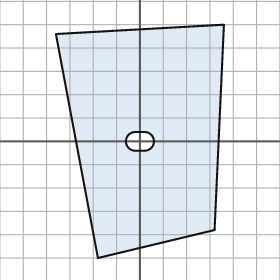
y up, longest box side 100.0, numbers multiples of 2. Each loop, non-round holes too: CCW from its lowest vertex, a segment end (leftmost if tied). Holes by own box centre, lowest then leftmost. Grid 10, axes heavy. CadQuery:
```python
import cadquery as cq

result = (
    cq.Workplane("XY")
    .moveTo(-18.0, -50.0)
    .lineTo(32.0, -38.0)
    .lineTo(36.0, 50.0)
    .lineTo(-36.0, 46.0)
    .close()
    .moveTo(-2.0, -4.0)
    .lineTo(2.0, -4.0)
    .threePointArc((6.0, 0.0), (2.0, 4.0))
    .lineTo(-2.0, 4.0)
    .threePointArc((-6.0, 0.0), (-2.0, -4.0))
    .close()
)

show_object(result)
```